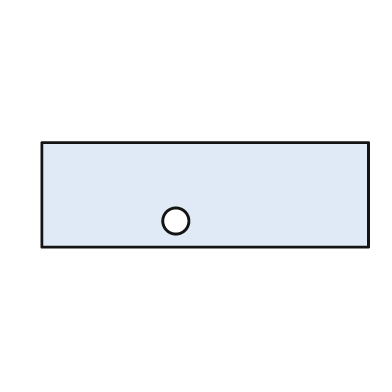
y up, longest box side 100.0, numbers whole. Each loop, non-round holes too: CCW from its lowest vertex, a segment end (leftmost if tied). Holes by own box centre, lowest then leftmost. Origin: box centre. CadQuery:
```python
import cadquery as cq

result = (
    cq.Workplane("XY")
    .moveTo(-50.0, -16.0)
    .lineTo(50.0, -16.0)
    .lineTo(50.0, 16.0)
    .lineTo(-50.0, 16.0)
    .close()
    .moveTo(-9.0, -8.0)
    .circle(4.0)
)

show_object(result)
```